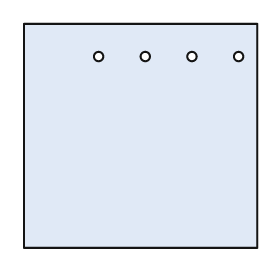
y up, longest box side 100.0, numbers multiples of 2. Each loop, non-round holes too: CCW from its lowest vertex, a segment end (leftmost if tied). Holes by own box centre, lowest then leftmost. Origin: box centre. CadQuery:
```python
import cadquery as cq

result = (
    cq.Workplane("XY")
    .moveTo(-50.0, -48.0)
    .lineTo(50.0, -48.0)
    .lineTo(50.0, 48.0)
    .lineTo(-50.0, 48.0)
    .close()
    .moveTo(-18.0, 34.0)
    .circle(2.0)
    .moveTo(2.0, 34.0)
    .circle(2.0)
    .moveTo(22.0, 34.0)
    .circle(2.0)
    .moveTo(42.0, 34.0)
    .circle(2.0)
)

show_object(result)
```